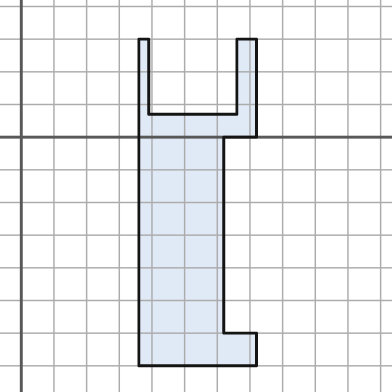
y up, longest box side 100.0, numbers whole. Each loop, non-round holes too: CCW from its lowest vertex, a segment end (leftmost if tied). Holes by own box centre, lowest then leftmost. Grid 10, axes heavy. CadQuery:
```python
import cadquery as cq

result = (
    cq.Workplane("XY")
    .moveTo(36.0, -70.0)
    .lineTo(72.0, -70.0)
    .lineTo(72.0, -60.0)
    .lineTo(62.0, -60.0)
    .lineTo(62.0, 0.0)
    .lineTo(72.0, 0.0)
    .lineTo(72.0, 30.0)
    .lineTo(66.0, 30.0)
    .lineTo(66.0, 7.0)
    .lineTo(39.0, 7.0)
    .lineTo(39.0, 30.0)
    .lineTo(36.0, 30.0)
    .close()
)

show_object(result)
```